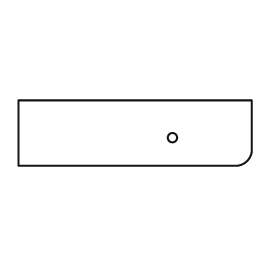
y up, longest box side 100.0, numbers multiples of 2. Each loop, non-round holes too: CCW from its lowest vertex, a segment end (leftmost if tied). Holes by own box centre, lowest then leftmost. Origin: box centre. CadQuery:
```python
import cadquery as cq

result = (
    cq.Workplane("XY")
    .moveTo(-50.0, -14.0)
    .lineTo(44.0, -14.0)
    .threePointArc((48.0, -12.0), (50.0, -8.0))
    .lineTo(50.0, 14.0)
    .lineTo(-50.0, 14.0)
    .close()
    .moveTo(16.0, -2.0)
    .circle(2.0)
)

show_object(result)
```